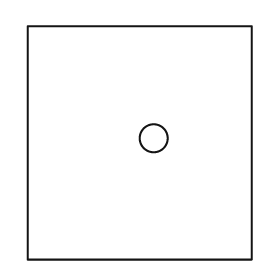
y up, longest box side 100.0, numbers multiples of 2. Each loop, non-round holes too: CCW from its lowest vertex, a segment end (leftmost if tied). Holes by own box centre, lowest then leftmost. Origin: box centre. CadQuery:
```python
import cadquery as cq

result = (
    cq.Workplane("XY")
    .moveTo(-48.0, -50.0)
    .lineTo(48.0, -50.0)
    .lineTo(48.0, 50.0)
    .lineTo(-48.0, 50.0)
    .close()
    .moveTo(6.0, 2.0)
    .circle(6.0)
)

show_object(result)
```